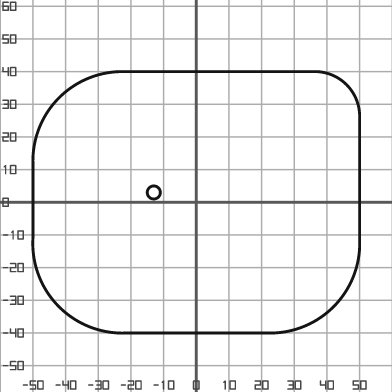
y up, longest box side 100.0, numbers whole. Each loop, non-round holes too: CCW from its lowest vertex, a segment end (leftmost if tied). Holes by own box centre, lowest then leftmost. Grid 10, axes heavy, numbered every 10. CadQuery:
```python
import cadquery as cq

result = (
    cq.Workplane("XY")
    .moveTo(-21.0, -40.0)
    .lineTo(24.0, -40.0)
    .threePointArc((42.0, -32.0), (50.0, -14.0))
    .lineTo(50.0, 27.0)
    .threePointArc((46.0, 36.0), (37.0, 40.0))
    .lineTo(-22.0, 40.0)
    .threePointArc((-42.0, 32.0), (-50.0, 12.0))
    .lineTo(-50.0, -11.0)
    .threePointArc((-42.0, -32.0), (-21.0, -40.0))
    .close()
    .moveTo(-13.0, 3.0)
    .circle(2.0)
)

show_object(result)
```